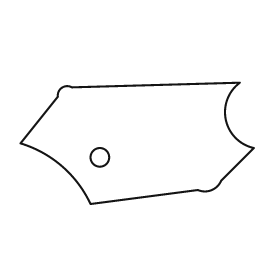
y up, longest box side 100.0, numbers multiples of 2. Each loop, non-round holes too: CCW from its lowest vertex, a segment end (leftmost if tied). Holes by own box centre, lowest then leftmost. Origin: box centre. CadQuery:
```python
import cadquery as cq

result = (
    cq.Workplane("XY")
    .moveTo(-20.0, -26.0)
    .lineTo(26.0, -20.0)
    .threePointArc((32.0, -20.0), (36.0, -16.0))
    .lineTo(50.0, -2.0)
    .threePointArc((38.0, 10.0), (44.0, 26.0))
    .lineTo(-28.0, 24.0)
    .threePointArc((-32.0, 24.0), (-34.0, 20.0))
    .lineTo(-50.0, 0.0)
    .threePointArc((-32.0, -10.0), (-20.0, -26.0))
    .close()
    .moveTo(-16.0, -6.0)
    .circle(4.0)
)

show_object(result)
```